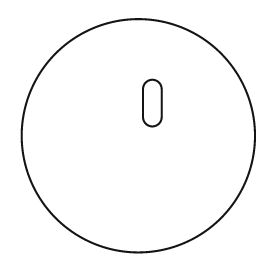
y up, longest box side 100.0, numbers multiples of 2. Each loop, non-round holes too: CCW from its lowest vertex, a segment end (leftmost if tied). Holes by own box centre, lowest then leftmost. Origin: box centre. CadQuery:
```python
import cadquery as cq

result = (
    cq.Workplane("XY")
    .moveTo(0.0, 0.0)
    .circle(50.0)
    .moveTo(2.0, 8.0)
    .threePointArc((6.0, 4.0), (10.0, 8.0))
    .lineTo(10.0, 20.0)
    .threePointArc((6.0, 24.0), (2.0, 20.0))
    .close()
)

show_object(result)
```